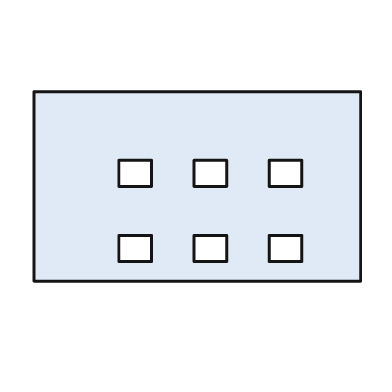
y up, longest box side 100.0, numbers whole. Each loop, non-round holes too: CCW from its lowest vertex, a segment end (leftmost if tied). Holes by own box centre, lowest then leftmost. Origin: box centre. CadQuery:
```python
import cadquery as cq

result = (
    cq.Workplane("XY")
    .moveTo(-50.0, -29.0)
    .lineTo(50.0, -29.0)
    .lineTo(50.0, 29.0)
    .lineTo(-50.0, 29.0)
    .close()
    .moveTo(-24.0, -23.0)
    .lineTo(-14.0, -23.0)
    .lineTo(-14.0, -15.0)
    .lineTo(-24.0, -15.0)
    .close()
    .moveTo(-1.0, -23.0)
    .lineTo(9.0, -23.0)
    .lineTo(9.0, -15.0)
    .lineTo(-1.0, -15.0)
    .close()
    .moveTo(22.0, -23.0)
    .lineTo(32.0, -23.0)
    .lineTo(32.0, -15.0)
    .lineTo(22.0, -15.0)
    .close()
    .moveTo(-24.0, 0.0)
    .lineTo(-14.0, 0.0)
    .lineTo(-14.0, 8.0)
    .lineTo(-24.0, 8.0)
    .close()
    .moveTo(-1.0, 0.0)
    .lineTo(9.0, 0.0)
    .lineTo(9.0, 8.0)
    .lineTo(-1.0, 8.0)
    .close()
    .moveTo(22.0, 0.0)
    .lineTo(32.0, 0.0)
    .lineTo(32.0, 8.0)
    .lineTo(22.0, 8.0)
    .close()
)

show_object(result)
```